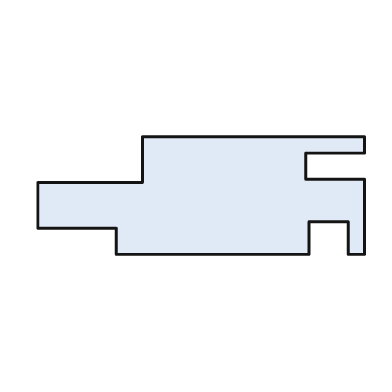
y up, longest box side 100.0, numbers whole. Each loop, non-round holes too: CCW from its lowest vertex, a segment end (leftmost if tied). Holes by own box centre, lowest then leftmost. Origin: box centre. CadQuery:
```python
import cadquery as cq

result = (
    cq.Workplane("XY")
    .moveTo(-26.0, -18.0)
    .lineTo(33.0, -18.0)
    .lineTo(33.0, -8.0)
    .lineTo(45.0, -8.0)
    .lineTo(45.0, -18.0)
    .lineTo(50.0, -18.0)
    .lineTo(50.0, 5.0)
    .lineTo(32.0, 5.0)
    .lineTo(32.0, 13.0)
    .lineTo(50.0, 13.0)
    .lineTo(50.0, 18.0)
    .lineTo(-18.0, 18.0)
    .lineTo(-18.0, 4.0)
    .lineTo(-50.0, 4.0)
    .lineTo(-50.0, -10.0)
    .lineTo(-26.0, -10.0)
    .close()
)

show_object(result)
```